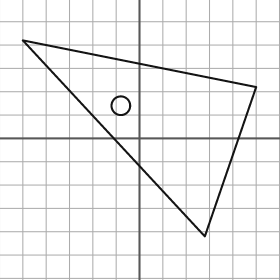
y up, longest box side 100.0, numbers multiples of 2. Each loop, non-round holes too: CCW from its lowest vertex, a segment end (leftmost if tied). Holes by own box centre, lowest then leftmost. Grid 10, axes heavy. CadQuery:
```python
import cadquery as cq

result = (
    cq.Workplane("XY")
    .moveTo(28.0, -42.0)
    .lineTo(50.0, 22.0)
    .lineTo(-50.0, 42.0)
    .close()
    .moveTo(-8.0, 14.0)
    .circle(4.0)
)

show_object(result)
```